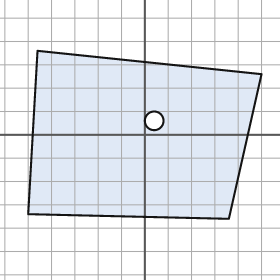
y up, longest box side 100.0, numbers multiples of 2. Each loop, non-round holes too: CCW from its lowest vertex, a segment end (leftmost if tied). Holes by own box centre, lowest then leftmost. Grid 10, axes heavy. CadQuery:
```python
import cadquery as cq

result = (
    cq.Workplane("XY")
    .moveTo(36.0, -36.0)
    .lineTo(50.0, 26.0)
    .lineTo(-46.0, 36.0)
    .lineTo(-50.0, -34.0)
    .close()
    .moveTo(4.0, 6.0)
    .circle(4.0)
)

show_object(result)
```